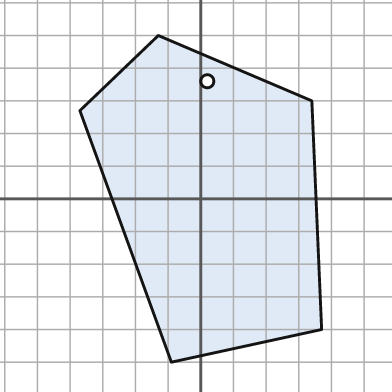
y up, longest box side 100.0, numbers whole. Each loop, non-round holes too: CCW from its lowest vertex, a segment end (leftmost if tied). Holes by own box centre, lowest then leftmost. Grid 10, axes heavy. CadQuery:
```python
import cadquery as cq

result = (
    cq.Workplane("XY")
    .moveTo(-9.0, -50.0)
    .lineTo(37.0, -40.0)
    .lineTo(34.0, 30.0)
    .lineTo(-13.0, 50.0)
    .lineTo(-37.0, 27.0)
    .close()
    .moveTo(2.0, 36.0)
    .circle(2.0)
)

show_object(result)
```